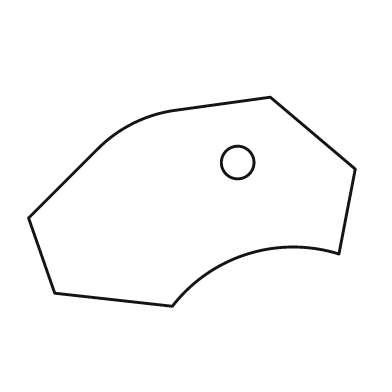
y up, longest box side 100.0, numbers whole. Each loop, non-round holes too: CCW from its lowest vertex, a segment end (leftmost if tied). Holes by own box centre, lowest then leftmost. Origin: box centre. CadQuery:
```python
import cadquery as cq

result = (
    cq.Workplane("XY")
    .moveTo(-6.0, -32.0)
    .threePointArc((17.0, -16.0), (45.0, -16.0))
    .lineTo(50.0, 10.0)
    .lineTo(24.0, 32.0)
    .lineTo(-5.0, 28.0)
    .threePointArc((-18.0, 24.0), (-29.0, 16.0))
    .lineTo(-50.0, -5.0)
    .lineTo(-42.0, -28.0)
    .close()
    .moveTo(14.0, 12.0)
    .circle(5.0)
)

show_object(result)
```